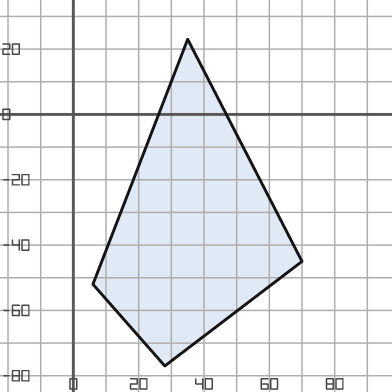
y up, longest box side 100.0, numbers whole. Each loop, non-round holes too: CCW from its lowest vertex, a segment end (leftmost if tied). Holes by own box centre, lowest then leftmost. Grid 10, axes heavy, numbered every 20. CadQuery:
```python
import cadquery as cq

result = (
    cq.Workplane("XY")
    .moveTo(28.0, -77.0)
    .lineTo(70.0, -45.0)
    .lineTo(35.0, 23.0)
    .lineTo(6.0, -52.0)
    .close()
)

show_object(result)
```